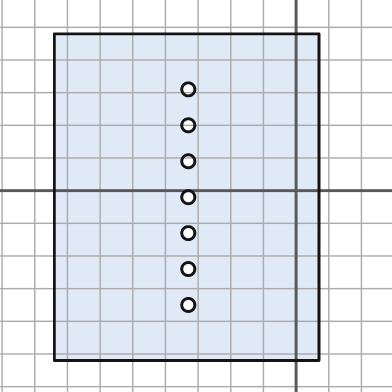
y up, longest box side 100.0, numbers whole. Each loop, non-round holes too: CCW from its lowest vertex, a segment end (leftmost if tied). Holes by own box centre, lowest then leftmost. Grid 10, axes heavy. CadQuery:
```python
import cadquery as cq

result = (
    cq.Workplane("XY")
    .moveTo(-74.0, -52.0)
    .lineTo(7.0, -52.0)
    .lineTo(7.0, 48.0)
    .lineTo(-74.0, 48.0)
    .close()
    .moveTo(-33.0, -35.0)
    .circle(2.0)
    .moveTo(-33.0, -24.0)
    .circle(2.0)
    .moveTo(-33.0, -13.0)
    .circle(2.0)
    .moveTo(-33.0, -2.0)
    .circle(2.0)
    .moveTo(-33.0, 9.0)
    .circle(2.0)
    .moveTo(-33.0, 20.0)
    .circle(2.0)
    .moveTo(-33.0, 31.0)
    .circle(2.0)
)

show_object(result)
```